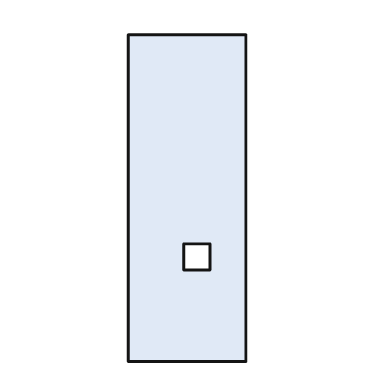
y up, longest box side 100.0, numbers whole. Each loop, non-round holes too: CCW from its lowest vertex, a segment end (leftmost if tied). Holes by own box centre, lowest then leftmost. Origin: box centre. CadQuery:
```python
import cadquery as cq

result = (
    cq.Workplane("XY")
    .moveTo(-18.0, -50.0)
    .lineTo(18.0, -50.0)
    .lineTo(18.0, 50.0)
    .lineTo(-18.0, 50.0)
    .close()
    .moveTo(-1.0, -22.0)
    .lineTo(7.0, -22.0)
    .lineTo(7.0, -14.0)
    .lineTo(-1.0, -14.0)
    .close()
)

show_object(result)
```